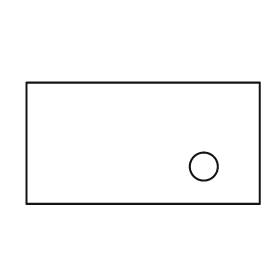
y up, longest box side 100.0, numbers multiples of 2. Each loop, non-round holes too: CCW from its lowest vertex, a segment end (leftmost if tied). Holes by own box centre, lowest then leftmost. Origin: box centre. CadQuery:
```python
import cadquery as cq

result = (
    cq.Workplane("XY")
    .moveTo(-50.0, -26.0)
    .lineTo(50.0, -26.0)
    .lineTo(50.0, 26.0)
    .lineTo(-50.0, 26.0)
    .close()
    .moveTo(26.0, -10.0)
    .circle(6.0)
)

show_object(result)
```